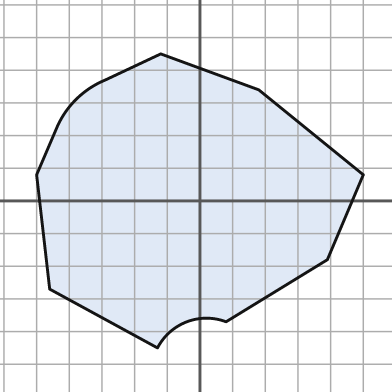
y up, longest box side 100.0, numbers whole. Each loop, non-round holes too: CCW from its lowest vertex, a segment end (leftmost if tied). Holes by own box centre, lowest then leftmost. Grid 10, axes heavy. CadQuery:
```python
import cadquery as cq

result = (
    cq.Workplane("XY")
    .moveTo(-13.0, -45.0)
    .threePointArc((-4.0, -37.0), (8.0, -37.0))
    .lineTo(39.0, -18.0)
    .lineTo(50.0, 8.0)
    .lineTo(18.0, 34.0)
    .lineTo(-12.0, 45.0)
    .lineTo(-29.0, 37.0)
    .threePointArc((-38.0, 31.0), (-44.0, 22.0))
    .lineTo(-50.0, 8.0)
    .lineTo(-46.0, -27.0)
    .close()
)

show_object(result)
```